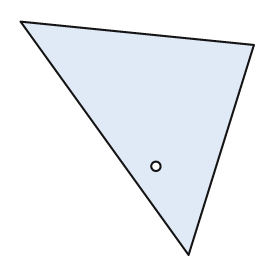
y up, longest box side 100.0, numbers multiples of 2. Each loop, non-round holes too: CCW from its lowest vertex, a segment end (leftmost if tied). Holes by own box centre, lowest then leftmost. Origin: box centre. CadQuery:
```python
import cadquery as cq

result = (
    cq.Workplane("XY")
    .moveTo(22.0, -50.0)
    .lineTo(50.0, 40.0)
    .lineTo(-50.0, 50.0)
    .close()
    .moveTo(8.0, -12.0)
    .circle(2.0)
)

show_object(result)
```